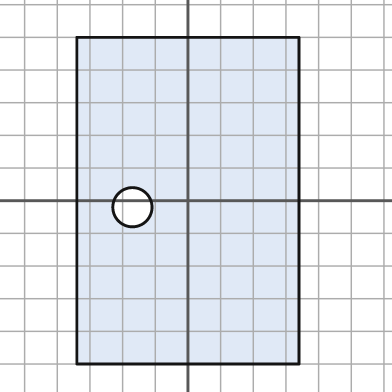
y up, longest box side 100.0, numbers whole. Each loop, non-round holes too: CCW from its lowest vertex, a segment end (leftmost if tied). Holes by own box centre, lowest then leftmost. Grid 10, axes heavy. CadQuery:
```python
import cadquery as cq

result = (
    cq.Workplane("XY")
    .moveTo(-34.0, -50.0)
    .lineTo(34.0, -50.0)
    .lineTo(34.0, 50.0)
    .lineTo(-34.0, 50.0)
    .close()
    .moveTo(-17.0, -2.0)
    .circle(6.0)
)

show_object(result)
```